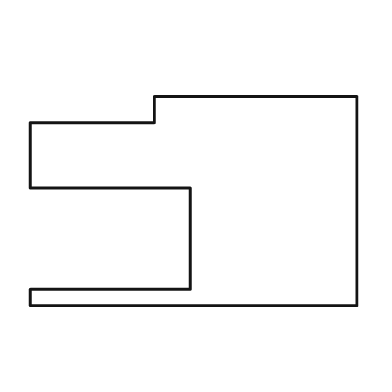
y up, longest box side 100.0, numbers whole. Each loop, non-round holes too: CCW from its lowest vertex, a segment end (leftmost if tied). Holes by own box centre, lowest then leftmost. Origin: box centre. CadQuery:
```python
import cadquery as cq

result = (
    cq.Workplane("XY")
    .moveTo(-50.0, -32.0)
    .lineTo(50.0, -32.0)
    .lineTo(50.0, 32.0)
    .lineTo(-12.0, 32.0)
    .lineTo(-12.0, 24.0)
    .lineTo(-50.0, 24.0)
    .lineTo(-50.0, 4.0)
    .lineTo(-1.0, 4.0)
    .lineTo(-1.0, -27.0)
    .lineTo(-50.0, -27.0)
    .close()
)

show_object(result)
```